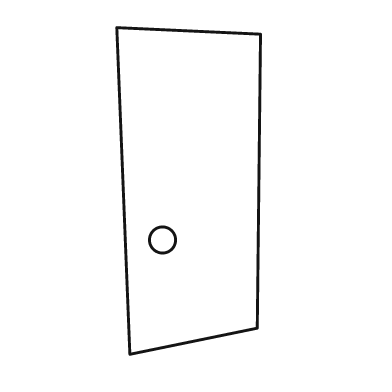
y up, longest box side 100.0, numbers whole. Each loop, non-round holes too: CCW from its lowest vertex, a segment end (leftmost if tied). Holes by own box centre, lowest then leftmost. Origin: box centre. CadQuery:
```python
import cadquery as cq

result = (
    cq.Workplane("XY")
    .moveTo(-18.0, -50.0)
    .lineTo(21.0, -42.0)
    .lineTo(22.0, 48.0)
    .lineTo(-22.0, 50.0)
    .close()
    .moveTo(-8.0, -15.0)
    .circle(4.0)
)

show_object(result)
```